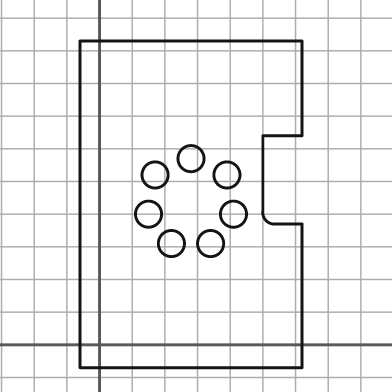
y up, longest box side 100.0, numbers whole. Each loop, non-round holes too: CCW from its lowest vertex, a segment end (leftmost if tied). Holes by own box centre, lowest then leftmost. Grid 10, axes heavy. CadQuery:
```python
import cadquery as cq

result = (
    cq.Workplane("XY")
    .moveTo(-6.0, -7.0)
    .lineTo(62.0, -7.0)
    .lineTo(62.0, 37.0)
    .lineTo(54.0, 37.0)
    .threePointArc((51.0, 38.0), (50.0, 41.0))
    .lineTo(50.0, 64.0)
    .lineTo(62.0, 64.0)
    .lineTo(62.0, 93.0)
    .lineTo(-6.0, 93.0)
    .close()
    .moveTo(22.0, 31.0)
    .circle(4.0)
    .moveTo(34.0, 31.0)
    .circle(4.0)
    .moveTo(15.0, 40.0)
    .circle(4.0)
    .moveTo(41.0, 40.0)
    .circle(4.0)
    .moveTo(17.0, 52.0)
    .circle(4.0)
    .moveTo(39.0, 52.0)
    .circle(4.0)
    .moveTo(28.0, 57.0)
    .circle(4.0)
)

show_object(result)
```